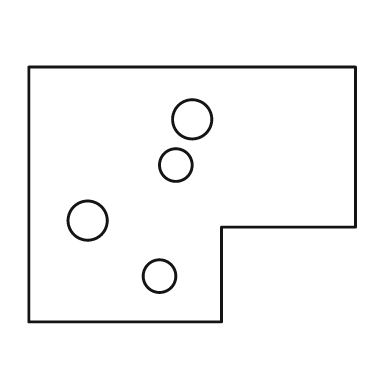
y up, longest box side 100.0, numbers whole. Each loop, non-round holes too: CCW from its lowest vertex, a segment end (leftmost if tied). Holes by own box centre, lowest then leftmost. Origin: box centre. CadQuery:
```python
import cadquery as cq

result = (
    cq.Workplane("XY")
    .moveTo(-50.0, -39.0)
    .lineTo(9.0, -39.0)
    .lineTo(9.0, -10.0)
    .lineTo(50.0, -10.0)
    .lineTo(50.0, 39.0)
    .lineTo(-50.0, 39.0)
    .close()
    .moveTo(-10.0, -25.0)
    .circle(5.0)
    .moveTo(-32.0, -8.0)
    .circle(6.0)
    .moveTo(-5.0, 9.0)
    .circle(5.0)
    .moveTo(0.0, 23.0)
    .circle(6.0)
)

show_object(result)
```